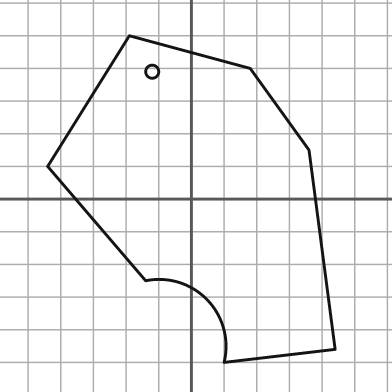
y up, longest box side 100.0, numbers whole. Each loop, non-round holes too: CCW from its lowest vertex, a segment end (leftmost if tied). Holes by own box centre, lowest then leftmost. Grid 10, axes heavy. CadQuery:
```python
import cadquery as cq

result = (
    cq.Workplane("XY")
    .moveTo(10.0, -50.0)
    .lineTo(44.0, -46.0)
    .lineTo(36.0, 15.0)
    .lineTo(18.0, 40.0)
    .lineTo(-19.0, 50.0)
    .lineTo(-44.0, 10.0)
    .lineTo(-14.0, -25.0)
    .threePointArc((5.0, -31.0), (10.0, -50.0))
    .close()
    .moveTo(-12.0, 39.0)
    .circle(2.0)
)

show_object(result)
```